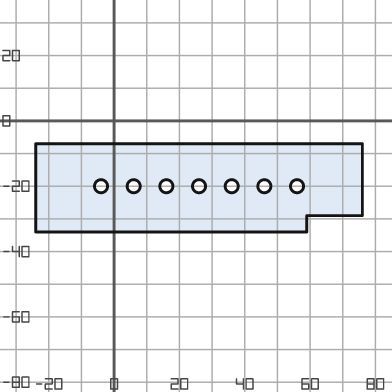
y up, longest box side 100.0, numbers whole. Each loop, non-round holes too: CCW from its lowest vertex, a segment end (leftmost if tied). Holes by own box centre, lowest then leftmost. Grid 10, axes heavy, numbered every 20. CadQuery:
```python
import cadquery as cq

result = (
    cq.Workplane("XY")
    .moveTo(-24.0, -34.0)
    .lineTo(59.0, -34.0)
    .lineTo(59.0, -29.0)
    .lineTo(76.0, -29.0)
    .lineTo(76.0, -7.0)
    .lineTo(-24.0, -7.0)
    .close()
    .moveTo(-4.0, -20.0)
    .circle(2.0)
    .moveTo(6.0, -20.0)
    .circle(2.0)
    .moveTo(16.0, -20.0)
    .circle(2.0)
    .moveTo(26.0, -20.0)
    .circle(2.0)
    .moveTo(36.0, -20.0)
    .circle(2.0)
    .moveTo(46.0, -20.0)
    .circle(2.0)
    .moveTo(56.0, -20.0)
    .circle(2.0)
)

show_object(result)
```